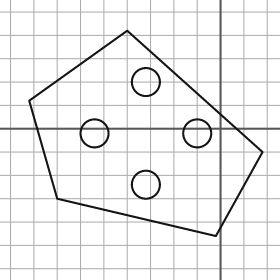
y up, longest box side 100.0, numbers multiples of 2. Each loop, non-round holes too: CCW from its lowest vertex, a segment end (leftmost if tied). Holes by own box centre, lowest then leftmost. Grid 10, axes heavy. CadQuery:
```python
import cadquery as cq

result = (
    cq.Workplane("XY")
    .moveTo(-2.0, -46.0)
    .lineTo(18.0, -10.0)
    .lineTo(-40.0, 42.0)
    .lineTo(-82.0, 12.0)
    .lineTo(-70.0, -30.0)
    .close()
    .moveTo(-32.0, -24.0)
    .circle(6.0)
    .moveTo(-54.0, -2.0)
    .circle(6.0)
    .moveTo(-10.0, -2.0)
    .circle(6.0)
    .moveTo(-32.0, 20.0)
    .circle(6.0)
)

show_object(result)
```